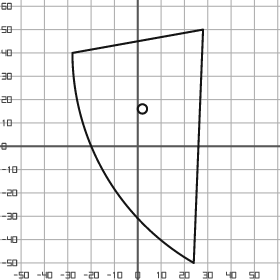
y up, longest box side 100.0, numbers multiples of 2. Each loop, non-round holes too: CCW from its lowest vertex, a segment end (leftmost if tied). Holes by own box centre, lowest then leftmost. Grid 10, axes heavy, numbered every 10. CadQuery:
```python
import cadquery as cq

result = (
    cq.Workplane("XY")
    .moveTo(24.0, -50.0)
    .lineTo(28.0, 50.0)
    .lineTo(-28.0, 40.0)
    .threePointArc((-14.0, -12.0), (24.0, -50.0))
    .close()
    .moveTo(2.0, 16.0)
    .circle(2.0)
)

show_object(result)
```